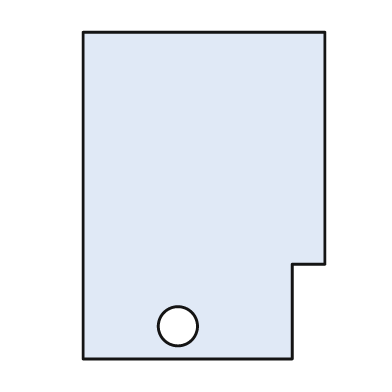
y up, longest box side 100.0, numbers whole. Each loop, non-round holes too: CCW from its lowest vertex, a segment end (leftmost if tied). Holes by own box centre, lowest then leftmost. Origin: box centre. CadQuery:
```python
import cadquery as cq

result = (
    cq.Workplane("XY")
    .moveTo(-37.0, -50.0)
    .lineTo(27.0, -50.0)
    .lineTo(27.0, -21.0)
    .lineTo(37.0, -21.0)
    .lineTo(37.0, 50.0)
    .lineTo(-37.0, 50.0)
    .close()
    .moveTo(-8.0, -40.0)
    .circle(6.0)
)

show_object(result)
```